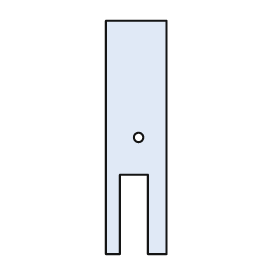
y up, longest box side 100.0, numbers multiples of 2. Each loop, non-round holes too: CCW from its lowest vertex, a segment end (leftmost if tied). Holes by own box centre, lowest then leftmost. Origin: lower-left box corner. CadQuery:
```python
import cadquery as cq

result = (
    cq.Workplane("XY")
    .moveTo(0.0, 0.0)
    .lineTo(6.0, 0.0)
    .lineTo(6.0, 34.0)
    .lineTo(18.0, 34.0)
    .lineTo(18.0, 0.0)
    .lineTo(26.0, 0.0)
    .lineTo(26.0, 100.0)
    .lineTo(0.0, 100.0)
    .close()
    .moveTo(14.0, 50.0)
    .circle(2.0)
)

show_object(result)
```